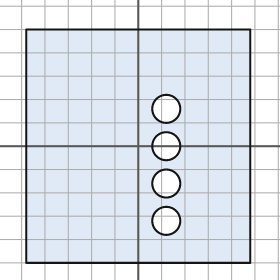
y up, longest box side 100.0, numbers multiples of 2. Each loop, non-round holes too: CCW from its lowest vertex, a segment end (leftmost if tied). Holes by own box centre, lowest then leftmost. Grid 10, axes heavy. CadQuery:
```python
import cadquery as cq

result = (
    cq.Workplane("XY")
    .moveTo(-48.0, -50.0)
    .lineTo(48.0, -50.0)
    .lineTo(48.0, 50.0)
    .lineTo(-48.0, 50.0)
    .close()
    .moveTo(12.0, -32.0)
    .circle(6.0)
    .moveTo(12.0, -16.0)
    .circle(6.0)
    .moveTo(12.0, 0.0)
    .circle(6.0)
    .moveTo(12.0, 16.0)
    .circle(6.0)
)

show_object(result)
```